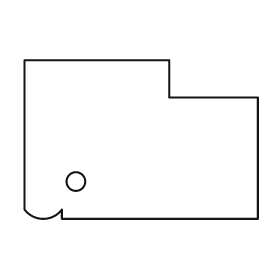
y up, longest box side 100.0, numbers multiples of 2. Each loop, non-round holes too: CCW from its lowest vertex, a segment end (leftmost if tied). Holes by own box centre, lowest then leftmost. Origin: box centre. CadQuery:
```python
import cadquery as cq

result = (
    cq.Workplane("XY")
    .moveTo(-34.0, -34.0)
    .lineTo(50.0, -34.0)
    .lineTo(50.0, 18.0)
    .lineTo(12.0, 18.0)
    .lineTo(12.0, 34.0)
    .lineTo(-50.0, 34.0)
    .lineTo(-50.0, -30.0)
    .threePointArc((-42.0, -34.0), (-34.0, -30.0))
    .close()
    .moveTo(-28.0, -18.0)
    .circle(4.0)
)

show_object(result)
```